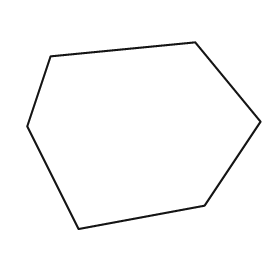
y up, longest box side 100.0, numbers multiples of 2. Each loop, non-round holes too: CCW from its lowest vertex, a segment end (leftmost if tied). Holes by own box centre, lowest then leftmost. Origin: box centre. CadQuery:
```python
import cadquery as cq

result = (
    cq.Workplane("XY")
    .moveTo(-28.0, -40.0)
    .lineTo(26.0, -30.0)
    .lineTo(50.0, 6.0)
    .lineTo(22.0, 40.0)
    .lineTo(-40.0, 34.0)
    .lineTo(-50.0, 4.0)
    .close()
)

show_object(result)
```